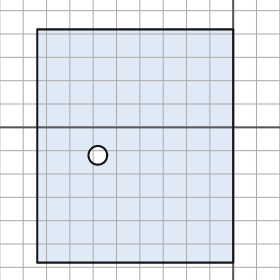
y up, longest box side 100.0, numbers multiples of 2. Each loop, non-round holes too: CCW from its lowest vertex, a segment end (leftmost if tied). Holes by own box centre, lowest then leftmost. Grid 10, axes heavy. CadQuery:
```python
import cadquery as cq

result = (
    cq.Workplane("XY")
    .moveTo(-84.0, -58.0)
    .lineTo(0.0, -58.0)
    .lineTo(0.0, 42.0)
    .lineTo(-84.0, 42.0)
    .close()
    .moveTo(-58.0, -12.0)
    .circle(4.0)
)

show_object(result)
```